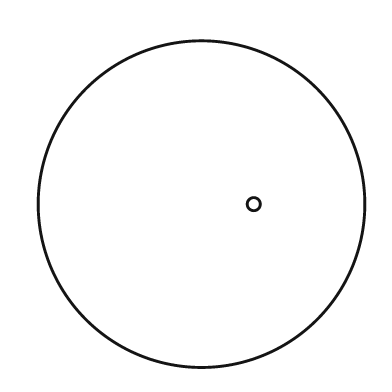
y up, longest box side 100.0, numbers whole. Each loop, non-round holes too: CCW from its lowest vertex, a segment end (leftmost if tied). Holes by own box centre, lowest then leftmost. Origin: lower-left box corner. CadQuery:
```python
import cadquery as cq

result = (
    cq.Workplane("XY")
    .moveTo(50.0, 50.0)
    .circle(50.0)
    .moveTo(66.0, 50.0)
    .circle(2.0)
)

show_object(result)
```